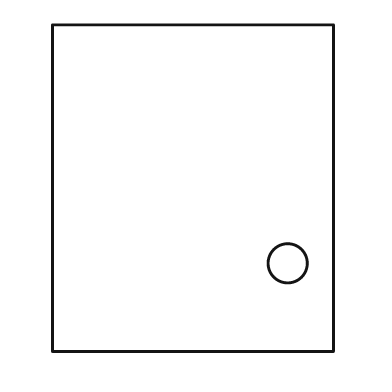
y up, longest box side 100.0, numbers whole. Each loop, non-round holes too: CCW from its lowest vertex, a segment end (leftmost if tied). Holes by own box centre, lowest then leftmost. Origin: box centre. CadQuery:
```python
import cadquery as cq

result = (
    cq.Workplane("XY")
    .moveTo(-43.0, -50.0)
    .lineTo(43.0, -50.0)
    .lineTo(43.0, 50.0)
    .lineTo(-43.0, 50.0)
    .close()
    .moveTo(29.0, -23.0)
    .circle(6.0)
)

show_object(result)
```